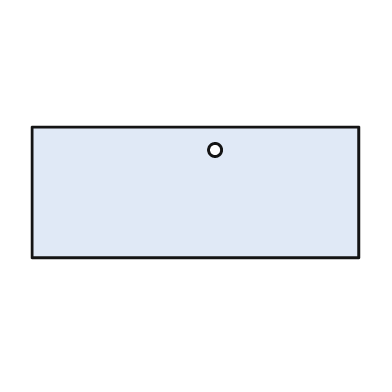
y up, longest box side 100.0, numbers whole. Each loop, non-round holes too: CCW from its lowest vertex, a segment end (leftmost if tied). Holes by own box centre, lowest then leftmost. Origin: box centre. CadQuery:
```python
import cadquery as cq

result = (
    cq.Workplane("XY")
    .moveTo(-50.0, -20.0)
    .lineTo(50.0, -20.0)
    .lineTo(50.0, 20.0)
    .lineTo(-50.0, 20.0)
    .close()
    .moveTo(6.0, 13.0)
    .circle(2.0)
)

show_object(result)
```